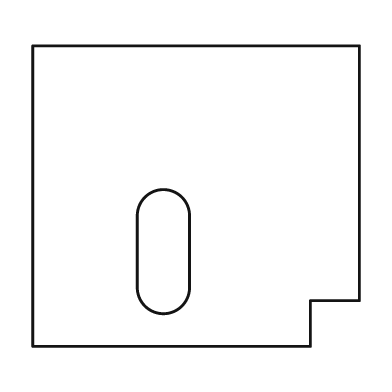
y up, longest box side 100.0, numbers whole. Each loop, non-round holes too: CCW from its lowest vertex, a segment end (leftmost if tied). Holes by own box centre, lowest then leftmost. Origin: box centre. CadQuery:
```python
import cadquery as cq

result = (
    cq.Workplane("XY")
    .moveTo(-50.0, -46.0)
    .lineTo(35.0, -46.0)
    .lineTo(35.0, -32.0)
    .lineTo(50.0, -32.0)
    .lineTo(50.0, 46.0)
    .lineTo(-50.0, 46.0)
    .close()
    .moveTo(-18.0, -28.0)
    .threePointArc((-10.0, -36.0), (-2.0, -28.0))
    .lineTo(-2.0, -6.0)
    .threePointArc((-10.0, 2.0), (-18.0, -6.0))
    .close()
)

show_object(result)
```